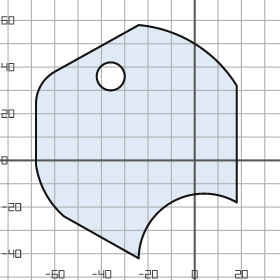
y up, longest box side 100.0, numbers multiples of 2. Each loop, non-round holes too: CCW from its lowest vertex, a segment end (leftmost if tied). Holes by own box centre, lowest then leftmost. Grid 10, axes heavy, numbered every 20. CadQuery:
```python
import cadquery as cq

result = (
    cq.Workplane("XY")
    .moveTo(-24.0, -42.0)
    .threePointArc((-10.0, -18.0), (18.0, -18.0))
    .lineTo(18.0, 32.0)
    .threePointArc((0.0, 50.0), (-24.0, 58.0))
    .lineTo(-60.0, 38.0)
    .threePointArc((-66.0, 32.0), (-68.0, 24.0))
    .lineTo(-68.0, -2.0)
    .threePointArc((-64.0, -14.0), (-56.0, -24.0))
    .close()
    .moveTo(-36.0, 36.0)
    .circle(6.0)
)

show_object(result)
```